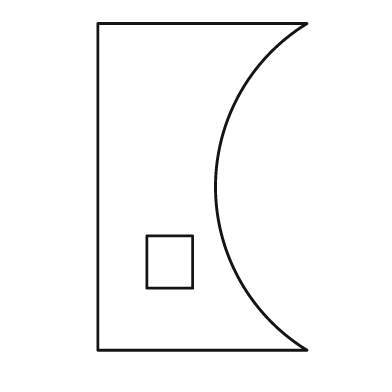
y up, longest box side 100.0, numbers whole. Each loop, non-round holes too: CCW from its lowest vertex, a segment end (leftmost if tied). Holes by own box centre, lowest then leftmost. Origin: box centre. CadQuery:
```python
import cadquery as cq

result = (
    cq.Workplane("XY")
    .moveTo(-32.0, -50.0)
    .lineTo(32.0, -50.0)
    .threePointArc((4.0, 0.0), (32.0, 50.0))
    .lineTo(-32.0, 50.0)
    .close()
    .moveTo(-17.0, -31.0)
    .lineTo(-3.0, -31.0)
    .lineTo(-3.0, -15.0)
    .lineTo(-17.0, -15.0)
    .close()
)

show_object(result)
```